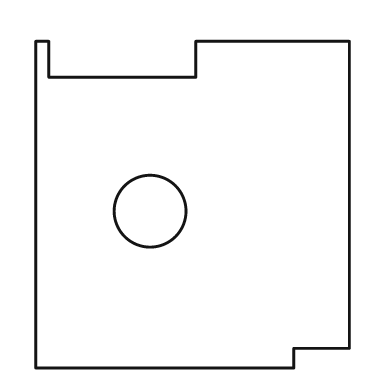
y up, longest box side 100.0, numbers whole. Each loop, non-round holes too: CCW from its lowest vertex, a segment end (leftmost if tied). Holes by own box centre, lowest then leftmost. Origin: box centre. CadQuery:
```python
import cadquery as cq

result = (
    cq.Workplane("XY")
    .moveTo(-48.0, -50.0)
    .lineTo(31.0, -50.0)
    .lineTo(31.0, -44.0)
    .lineTo(48.0, -44.0)
    .lineTo(48.0, 50.0)
    .lineTo(1.0, 50.0)
    .lineTo(1.0, 39.0)
    .lineTo(-44.0, 39.0)
    .lineTo(-44.0, 50.0)
    .lineTo(-48.0, 50.0)
    .close()
    .moveTo(-13.0, -2.0)
    .circle(11.0)
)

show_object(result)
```